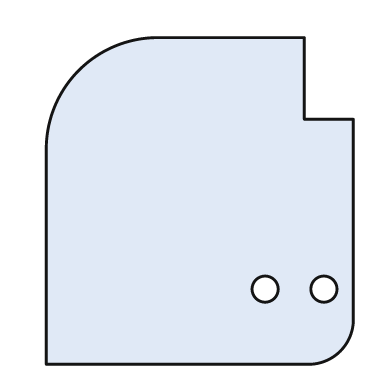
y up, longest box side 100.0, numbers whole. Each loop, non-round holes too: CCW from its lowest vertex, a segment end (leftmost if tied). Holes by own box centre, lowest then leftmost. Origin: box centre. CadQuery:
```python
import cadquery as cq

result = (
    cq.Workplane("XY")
    .moveTo(-47.0, -50.0)
    .lineTo(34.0, -50.0)
    .threePointArc((43.0, -46.0), (47.0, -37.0))
    .lineTo(47.0, 25.0)
    .lineTo(32.0, 25.0)
    .lineTo(32.0, 50.0)
    .lineTo(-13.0, 50.0)
    .threePointArc((-37.0, 40.0), (-47.0, 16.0))
    .close()
    .moveTo(20.0, -27.0)
    .circle(4.0)
    .moveTo(38.0, -27.0)
    .circle(4.0)
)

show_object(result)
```